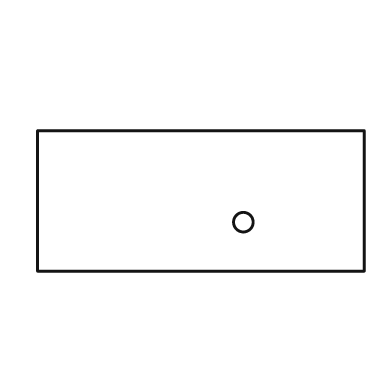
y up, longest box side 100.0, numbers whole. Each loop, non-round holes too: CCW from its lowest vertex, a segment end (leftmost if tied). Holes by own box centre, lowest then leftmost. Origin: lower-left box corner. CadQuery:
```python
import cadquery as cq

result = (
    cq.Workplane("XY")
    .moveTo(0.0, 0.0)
    .lineTo(100.0, 0.0)
    .lineTo(100.0, 43.0)
    .lineTo(0.0, 43.0)
    .close()
    .moveTo(63.0, 15.0)
    .circle(3.0)
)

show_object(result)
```